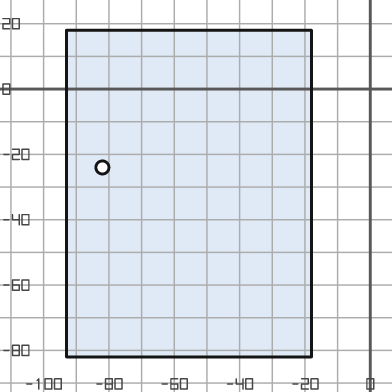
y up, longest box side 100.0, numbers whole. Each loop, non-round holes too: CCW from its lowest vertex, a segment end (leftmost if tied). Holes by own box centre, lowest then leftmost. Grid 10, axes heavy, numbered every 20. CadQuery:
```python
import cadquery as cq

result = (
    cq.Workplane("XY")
    .moveTo(-93.0, -82.0)
    .lineTo(-18.0, -82.0)
    .lineTo(-18.0, 18.0)
    .lineTo(-93.0, 18.0)
    .close()
    .moveTo(-82.0, -24.0)
    .circle(2.0)
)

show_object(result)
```